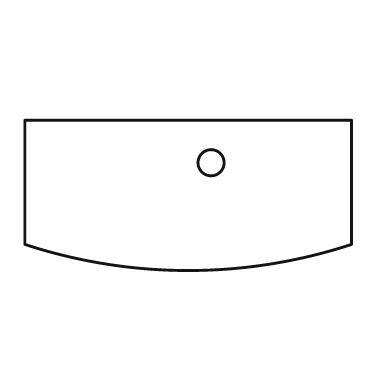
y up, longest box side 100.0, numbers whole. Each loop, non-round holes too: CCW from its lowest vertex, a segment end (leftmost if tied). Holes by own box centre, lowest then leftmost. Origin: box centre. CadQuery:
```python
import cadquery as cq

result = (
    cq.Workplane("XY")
    .moveTo(-50.0, -15.0)
    .threePointArc((0.0, -23.0), (50.0, -15.0))
    .lineTo(50.0, 23.0)
    .lineTo(-50.0, 23.0)
    .close()
    .moveTo(7.0, 10.0)
    .circle(4.0)
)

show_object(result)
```